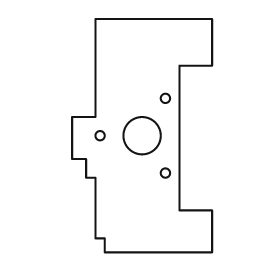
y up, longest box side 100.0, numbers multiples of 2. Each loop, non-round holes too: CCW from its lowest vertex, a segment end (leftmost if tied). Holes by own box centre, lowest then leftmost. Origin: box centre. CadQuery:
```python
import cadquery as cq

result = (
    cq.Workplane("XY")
    .moveTo(-16.0, -50.0)
    .lineTo(30.0, -50.0)
    .lineTo(30.0, -32.0)
    .lineTo(16.0, -32.0)
    .lineTo(16.0, 30.0)
    .lineTo(30.0, 30.0)
    .lineTo(30.0, 50.0)
    .lineTo(-20.0, 50.0)
    .lineTo(-20.0, 8.0)
    .lineTo(-30.0, 8.0)
    .lineTo(-30.0, -10.0)
    .lineTo(-24.0, -10.0)
    .lineTo(-24.0, -18.0)
    .lineTo(-20.0, -18.0)
    .lineTo(-20.0, -44.0)
    .lineTo(-16.0, -44.0)
    .close()
    .moveTo(10.0, -16.0)
    .circle(2.0)
    .moveTo(-18.0, 0.0)
    .circle(2.0)
    .moveTo(0.0, 0.0)
    .circle(8.0)
    .moveTo(10.0, 16.0)
    .circle(2.0)
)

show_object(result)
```